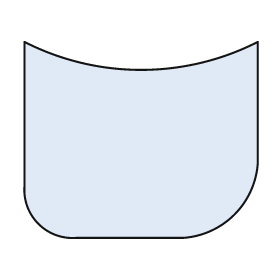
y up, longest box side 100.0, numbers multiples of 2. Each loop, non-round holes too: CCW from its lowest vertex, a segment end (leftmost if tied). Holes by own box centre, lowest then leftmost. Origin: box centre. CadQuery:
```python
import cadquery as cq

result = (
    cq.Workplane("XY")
    .moveTo(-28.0, -42.0)
    .lineTo(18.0, -42.0)
    .threePointArc((40.0, -32.0), (50.0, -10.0))
    .lineTo(50.0, 42.0)
    .threePointArc((0.0, 30.0), (-50.0, 42.0))
    .lineTo(-50.0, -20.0)
    .threePointArc((-44.0, -36.0), (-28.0, -42.0))
    .close()
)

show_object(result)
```